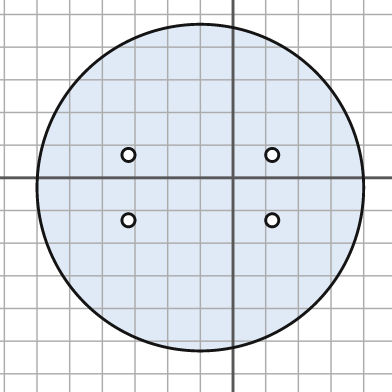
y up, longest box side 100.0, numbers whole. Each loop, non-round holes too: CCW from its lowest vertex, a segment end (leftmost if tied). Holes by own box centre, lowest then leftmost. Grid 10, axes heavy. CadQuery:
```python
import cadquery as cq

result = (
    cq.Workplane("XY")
    .moveTo(-10.0, -3.0)
    .circle(50.0)
    .moveTo(-32.0, -13.0)
    .circle(2.0)
    .moveTo(12.0, -13.0)
    .circle(2.0)
    .moveTo(-32.0, 7.0)
    .circle(2.0)
    .moveTo(12.0, 7.0)
    .circle(2.0)
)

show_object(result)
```